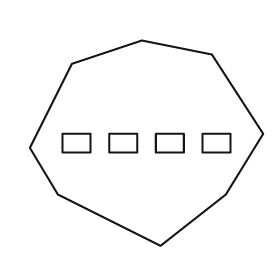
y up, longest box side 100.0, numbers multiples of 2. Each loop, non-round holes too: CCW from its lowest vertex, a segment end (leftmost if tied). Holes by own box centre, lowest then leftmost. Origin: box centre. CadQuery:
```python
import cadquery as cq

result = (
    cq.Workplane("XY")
    .moveTo(6.0, -44.0)
    .lineTo(34.0, -22.0)
    .lineTo(50.0, 4.0)
    .lineTo(28.0, 38.0)
    .lineTo(-2.0, 44.0)
    .lineTo(-32.0, 34.0)
    .lineTo(-50.0, -2.0)
    .lineTo(-38.0, -22.0)
    .close()
    .moveTo(-36.0, -4.0)
    .lineTo(-24.0, -4.0)
    .lineTo(-24.0, 4.0)
    .lineTo(-36.0, 4.0)
    .close()
    .moveTo(-16.0, -4.0)
    .lineTo(-4.0, -4.0)
    .lineTo(-4.0, 4.0)
    .lineTo(-16.0, 4.0)
    .close()
    .moveTo(4.0, -4.0)
    .lineTo(16.0, -4.0)
    .lineTo(16.0, 4.0)
    .lineTo(4.0, 4.0)
    .close()
    .moveTo(24.0, -4.0)
    .lineTo(36.0, -4.0)
    .lineTo(36.0, 4.0)
    .lineTo(24.0, 4.0)
    .close()
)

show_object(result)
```